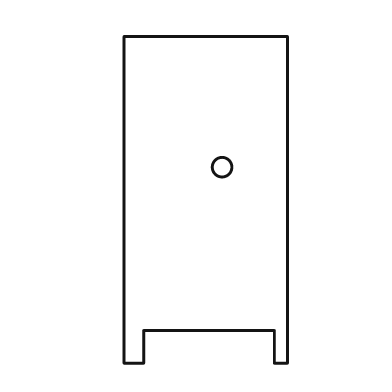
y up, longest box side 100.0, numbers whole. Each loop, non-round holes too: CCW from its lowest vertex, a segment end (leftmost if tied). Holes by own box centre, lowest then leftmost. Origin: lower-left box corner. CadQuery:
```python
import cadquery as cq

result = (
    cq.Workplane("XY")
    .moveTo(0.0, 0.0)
    .lineTo(6.0, 0.0)
    .lineTo(6.0, 10.0)
    .lineTo(46.0, 10.0)
    .lineTo(46.0, 0.0)
    .lineTo(50.0, 0.0)
    .lineTo(50.0, 100.0)
    .lineTo(0.0, 100.0)
    .close()
    .moveTo(30.0, 60.0)
    .circle(3.0)
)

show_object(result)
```